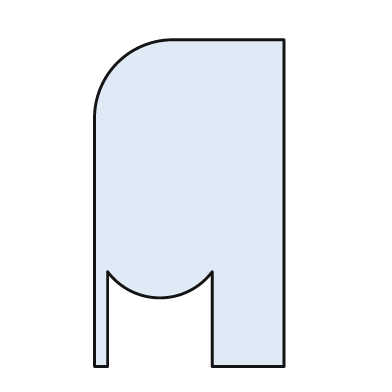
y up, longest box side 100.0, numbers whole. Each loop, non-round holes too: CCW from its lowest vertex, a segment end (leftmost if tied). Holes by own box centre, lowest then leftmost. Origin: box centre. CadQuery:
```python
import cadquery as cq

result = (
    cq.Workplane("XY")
    .moveTo(-29.0, -50.0)
    .lineTo(-25.0, -50.0)
    .lineTo(-25.0, -21.0)
    .threePointArc((-9.0, -29.0), (7.0, -21.0))
    .lineTo(7.0, -50.0)
    .lineTo(29.0, -50.0)
    .lineTo(29.0, 50.0)
    .lineTo(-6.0, 50.0)
    .threePointArc((-22.0, 43.0), (-29.0, 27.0))
    .close()
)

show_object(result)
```